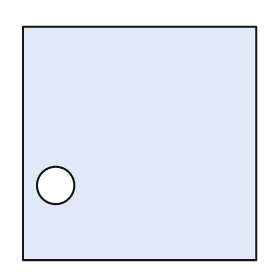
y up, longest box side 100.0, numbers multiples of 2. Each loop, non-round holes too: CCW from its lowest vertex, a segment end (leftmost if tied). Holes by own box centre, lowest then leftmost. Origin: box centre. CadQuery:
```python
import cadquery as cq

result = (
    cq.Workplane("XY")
    .moveTo(-50.0, -50.0)
    .lineTo(50.0, -50.0)
    .lineTo(50.0, 50.0)
    .lineTo(-50.0, 50.0)
    .close()
    .moveTo(-36.0, -18.0)
    .circle(8.0)
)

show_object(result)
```